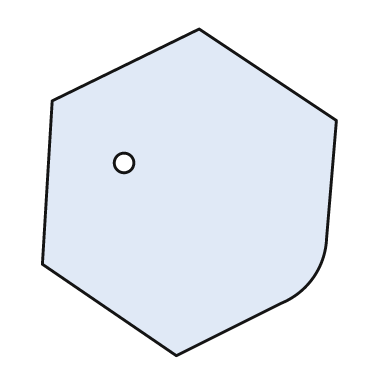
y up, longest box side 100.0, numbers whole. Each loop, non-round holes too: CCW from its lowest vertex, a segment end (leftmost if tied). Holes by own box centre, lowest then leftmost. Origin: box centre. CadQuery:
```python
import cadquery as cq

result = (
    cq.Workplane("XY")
    .moveTo(-4.0, -50.0)
    .lineTo(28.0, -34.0)
    .threePointArc((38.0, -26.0), (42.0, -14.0))
    .lineTo(45.0, 22.0)
    .lineTo(3.0, 50.0)
    .lineTo(-42.0, 28.0)
    .lineTo(-45.0, -22.0)
    .close()
    .moveTo(-20.0, 9.0)
    .circle(3.0)
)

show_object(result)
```